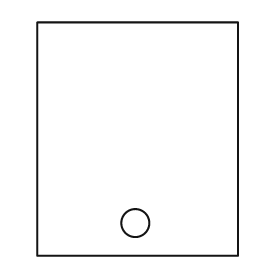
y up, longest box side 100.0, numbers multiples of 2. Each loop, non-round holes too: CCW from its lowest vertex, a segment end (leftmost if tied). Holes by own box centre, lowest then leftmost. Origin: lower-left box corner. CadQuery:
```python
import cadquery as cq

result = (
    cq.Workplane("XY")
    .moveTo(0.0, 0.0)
    .lineTo(86.0, 0.0)
    .lineTo(86.0, 100.0)
    .lineTo(0.0, 100.0)
    .close()
    .moveTo(42.0, 14.0)
    .circle(6.0)
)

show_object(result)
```